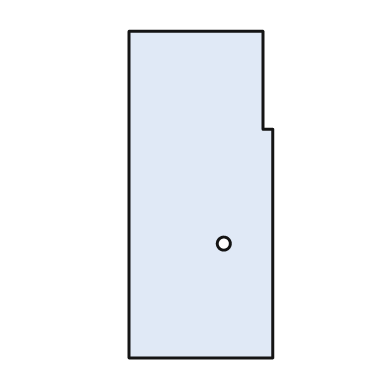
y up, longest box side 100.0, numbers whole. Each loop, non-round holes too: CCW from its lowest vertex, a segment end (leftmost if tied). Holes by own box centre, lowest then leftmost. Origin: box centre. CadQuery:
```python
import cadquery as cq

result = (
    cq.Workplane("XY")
    .moveTo(-22.0, -50.0)
    .lineTo(22.0, -50.0)
    .lineTo(22.0, 20.0)
    .lineTo(19.0, 20.0)
    .lineTo(19.0, 50.0)
    .lineTo(-22.0, 50.0)
    .close()
    .moveTo(7.0, -15.0)
    .circle(2.0)
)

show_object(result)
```